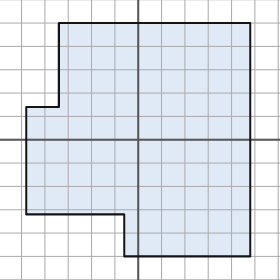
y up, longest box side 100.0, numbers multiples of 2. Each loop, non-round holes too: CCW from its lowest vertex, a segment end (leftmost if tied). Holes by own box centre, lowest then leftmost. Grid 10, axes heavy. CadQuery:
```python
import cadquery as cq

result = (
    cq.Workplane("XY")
    .moveTo(-6.0, -50.0)
    .lineTo(48.0, -50.0)
    .lineTo(48.0, 50.0)
    .lineTo(-34.0, 50.0)
    .lineTo(-34.0, 14.0)
    .lineTo(-48.0, 14.0)
    .lineTo(-48.0, -32.0)
    .lineTo(-6.0, -32.0)
    .close()
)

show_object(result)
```